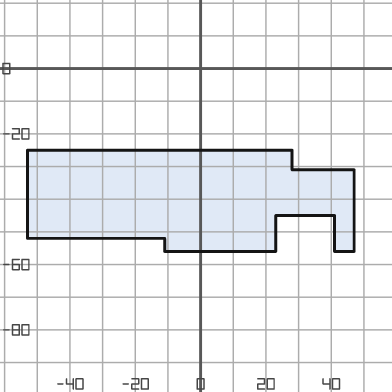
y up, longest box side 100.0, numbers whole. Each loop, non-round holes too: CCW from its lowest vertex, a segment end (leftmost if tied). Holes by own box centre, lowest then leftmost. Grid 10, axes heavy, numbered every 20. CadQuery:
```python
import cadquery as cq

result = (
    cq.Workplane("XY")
    .moveTo(-11.0, -56.0)
    .lineTo(23.0, -56.0)
    .lineTo(23.0, -45.0)
    .lineTo(41.0, -45.0)
    .lineTo(41.0, -56.0)
    .lineTo(47.0, -56.0)
    .lineTo(47.0, -31.0)
    .lineTo(28.0, -31.0)
    .lineTo(28.0, -25.0)
    .lineTo(-53.0, -25.0)
    .lineTo(-53.0, -52.0)
    .lineTo(-11.0, -52.0)
    .close()
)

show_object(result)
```